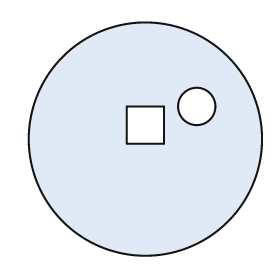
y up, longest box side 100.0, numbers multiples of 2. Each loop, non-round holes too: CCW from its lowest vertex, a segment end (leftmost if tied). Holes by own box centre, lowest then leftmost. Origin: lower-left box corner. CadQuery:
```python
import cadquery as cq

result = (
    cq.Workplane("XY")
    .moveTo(50.0, 50.0)
    .circle(50.0)
    .moveTo(42.0, 48.0)
    .lineTo(58.0, 48.0)
    .lineTo(58.0, 64.0)
    .lineTo(42.0, 64.0)
    .close()
    .moveTo(72.0, 64.0)
    .circle(8.0)
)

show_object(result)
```